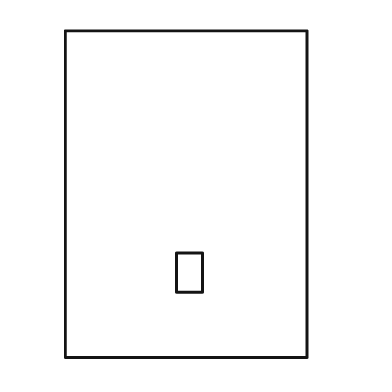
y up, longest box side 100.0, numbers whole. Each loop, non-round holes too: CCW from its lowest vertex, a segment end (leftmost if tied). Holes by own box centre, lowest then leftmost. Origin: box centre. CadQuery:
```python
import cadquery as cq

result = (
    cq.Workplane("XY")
    .moveTo(-37.0, -50.0)
    .lineTo(37.0, -50.0)
    .lineTo(37.0, 50.0)
    .lineTo(-37.0, 50.0)
    .close()
    .moveTo(-3.0, -30.0)
    .lineTo(5.0, -30.0)
    .lineTo(5.0, -18.0)
    .lineTo(-3.0, -18.0)
    .close()
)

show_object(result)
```